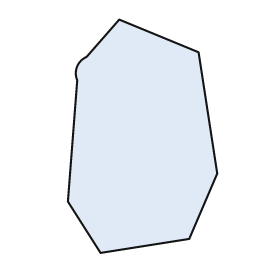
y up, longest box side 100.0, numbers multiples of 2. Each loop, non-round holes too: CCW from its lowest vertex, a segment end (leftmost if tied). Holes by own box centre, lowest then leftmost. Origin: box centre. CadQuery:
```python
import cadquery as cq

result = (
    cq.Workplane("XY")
    .moveTo(-18.0, -50.0)
    .lineTo(20.0, -44.0)
    .lineTo(32.0, -16.0)
    .lineTo(24.0, 36.0)
    .lineTo(-10.0, 50.0)
    .lineTo(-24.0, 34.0)
    .threePointArc((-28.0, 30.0), (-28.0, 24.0))
    .lineTo(-32.0, -28.0)
    .close()
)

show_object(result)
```